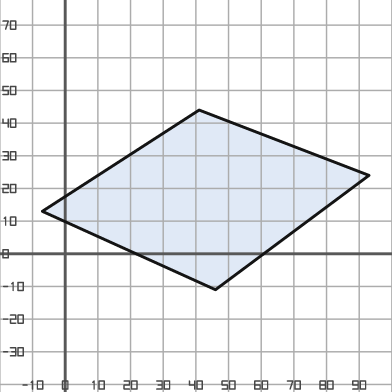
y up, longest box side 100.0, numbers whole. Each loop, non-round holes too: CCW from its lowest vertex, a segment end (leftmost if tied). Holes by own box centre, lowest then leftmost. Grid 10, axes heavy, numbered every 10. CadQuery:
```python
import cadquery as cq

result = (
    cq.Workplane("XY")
    .moveTo(46.0, -11.0)
    .lineTo(93.0, 24.0)
    .lineTo(41.0, 44.0)
    .lineTo(-7.0, 13.0)
    .close()
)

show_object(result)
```